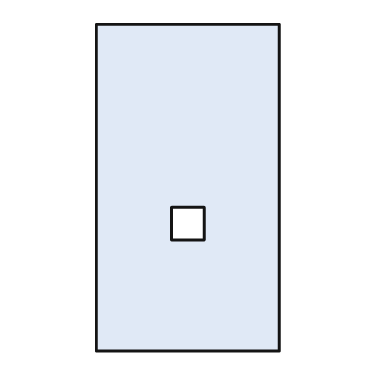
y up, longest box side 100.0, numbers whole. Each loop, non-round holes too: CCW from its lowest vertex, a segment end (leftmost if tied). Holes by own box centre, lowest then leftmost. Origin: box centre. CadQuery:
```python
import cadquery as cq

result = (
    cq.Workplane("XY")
    .moveTo(-28.0, -50.0)
    .lineTo(28.0, -50.0)
    .lineTo(28.0, 50.0)
    .lineTo(-28.0, 50.0)
    .close()
    .moveTo(-5.0, -16.0)
    .lineTo(5.0, -16.0)
    .lineTo(5.0, -6.0)
    .lineTo(-5.0, -6.0)
    .close()
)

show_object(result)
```